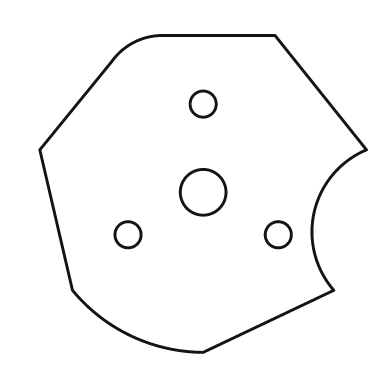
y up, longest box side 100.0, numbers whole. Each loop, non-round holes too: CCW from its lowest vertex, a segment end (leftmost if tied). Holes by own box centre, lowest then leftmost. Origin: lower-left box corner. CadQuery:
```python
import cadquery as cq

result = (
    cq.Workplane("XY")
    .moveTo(50.0, 0.0)
    .lineTo(90.0, 19.0)
    .threePointArc((84.0, 43.0), (100.0, 62.0))
    .lineTo(72.0, 97.0)
    .lineTo(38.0, 97.0)
    .threePointArc((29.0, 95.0), (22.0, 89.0))
    .lineTo(0.0, 62.0)
    .lineTo(10.0, 19.0)
    .threePointArc((28.0, 5.0), (50.0, 0.0))
    .close()
    .moveTo(27.0, 36.0)
    .circle(4.0)
    .moveTo(73.0, 36.0)
    .circle(4.0)
    .moveTo(50.0, 49.0)
    .circle(7.0)
    .moveTo(50.0, 76.0)
    .circle(4.0)
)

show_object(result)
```